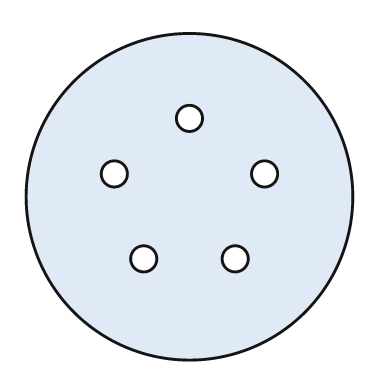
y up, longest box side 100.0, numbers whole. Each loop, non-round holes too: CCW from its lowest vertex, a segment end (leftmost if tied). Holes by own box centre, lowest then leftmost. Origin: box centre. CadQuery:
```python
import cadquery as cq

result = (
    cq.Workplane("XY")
    .moveTo(0.0, 0.0)
    .circle(50.0)
    .moveTo(-14.0, -19.0)
    .circle(4.0)
    .moveTo(14.0, -19.0)
    .circle(4.0)
    .moveTo(-23.0, 7.0)
    .circle(4.0)
    .moveTo(23.0, 7.0)
    .circle(4.0)
    .moveTo(0.0, 24.0)
    .circle(4.0)
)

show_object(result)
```